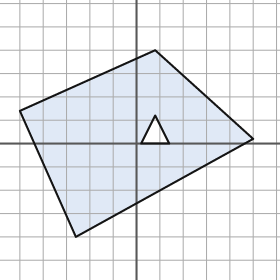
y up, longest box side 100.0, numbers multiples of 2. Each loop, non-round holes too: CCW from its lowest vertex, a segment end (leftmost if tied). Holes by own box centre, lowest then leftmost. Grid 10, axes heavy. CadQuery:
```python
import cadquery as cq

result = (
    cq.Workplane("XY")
    .moveTo(-26.0, -40.0)
    .lineTo(50.0, 2.0)
    .lineTo(8.0, 40.0)
    .lineTo(-50.0, 14.0)
    .close()
    .moveTo(2.0, 0.0)
    .lineTo(14.0, 0.0)
    .lineTo(8.0, 12.0)
    .close()
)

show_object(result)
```